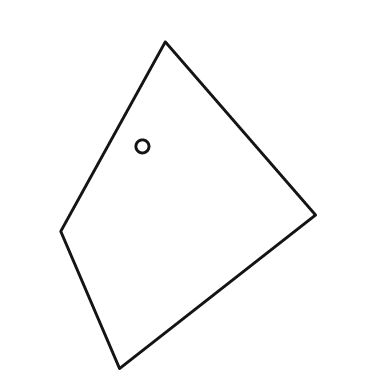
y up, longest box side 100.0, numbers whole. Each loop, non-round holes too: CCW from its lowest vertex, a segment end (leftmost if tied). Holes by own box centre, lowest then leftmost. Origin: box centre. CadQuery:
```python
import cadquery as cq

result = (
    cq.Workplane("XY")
    .moveTo(-21.0, -50.0)
    .lineTo(39.0, -3.0)
    .lineTo(-7.0, 50.0)
    .lineTo(-39.0, -8.0)
    .close()
    .moveTo(-14.0, 18.0)
    .circle(2.0)
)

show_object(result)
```